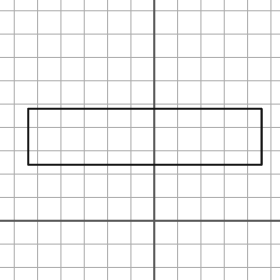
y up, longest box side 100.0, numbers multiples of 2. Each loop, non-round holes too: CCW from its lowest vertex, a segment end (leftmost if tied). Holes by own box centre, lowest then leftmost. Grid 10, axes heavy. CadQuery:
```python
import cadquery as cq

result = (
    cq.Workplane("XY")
    .moveTo(-54.0, 24.0)
    .lineTo(46.0, 24.0)
    .lineTo(46.0, 48.0)
    .lineTo(-54.0, 48.0)
    .close()
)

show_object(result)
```